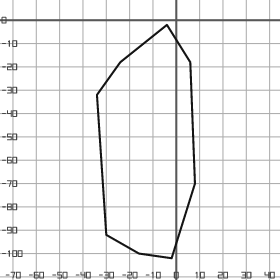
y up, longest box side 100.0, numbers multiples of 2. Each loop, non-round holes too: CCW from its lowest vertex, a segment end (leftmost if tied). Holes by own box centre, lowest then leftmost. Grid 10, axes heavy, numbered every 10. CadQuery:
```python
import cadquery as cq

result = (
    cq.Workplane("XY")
    .moveTo(-2.0, -102.0)
    .lineTo(8.0, -70.0)
    .lineTo(6.0, -18.0)
    .lineTo(-4.0, -2.0)
    .lineTo(-24.0, -18.0)
    .lineTo(-34.0, -32.0)
    .lineTo(-30.0, -92.0)
    .lineTo(-16.0, -100.0)
    .close()
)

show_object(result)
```